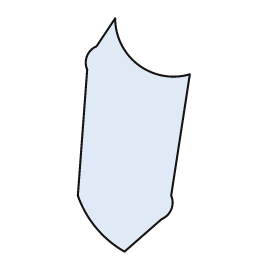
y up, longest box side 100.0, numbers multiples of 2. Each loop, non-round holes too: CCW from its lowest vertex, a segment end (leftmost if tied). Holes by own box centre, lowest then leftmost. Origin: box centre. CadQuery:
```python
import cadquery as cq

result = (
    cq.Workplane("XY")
    .moveTo(-4.0, -50.0)
    .lineTo(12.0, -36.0)
    .threePointArc((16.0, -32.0), (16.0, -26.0))
    .lineTo(24.0, 26.0)
    .threePointArc((2.0, 30.0), (-8.0, 50.0))
    .lineTo(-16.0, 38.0)
    .threePointArc((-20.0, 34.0), (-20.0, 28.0))
    .lineTo(-24.0, -26.0)
    .threePointArc((-16.0, -40.0), (-4.0, -50.0))
    .close()
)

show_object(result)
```